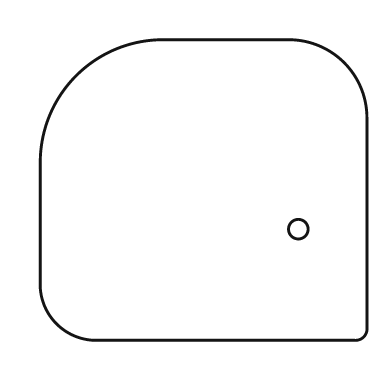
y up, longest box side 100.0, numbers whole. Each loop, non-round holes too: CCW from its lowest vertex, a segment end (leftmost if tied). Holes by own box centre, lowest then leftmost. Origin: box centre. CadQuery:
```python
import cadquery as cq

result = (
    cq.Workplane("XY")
    .moveTo(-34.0, -46.0)
    .lineTo(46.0, -46.0)
    .threePointArc((49.0, -45.0), (50.0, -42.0))
    .lineTo(50.0, 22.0)
    .threePointArc((43.0, 39.0), (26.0, 46.0))
    .lineTo(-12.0, 46.0)
    .threePointArc((-39.0, 35.0), (-50.0, 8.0))
    .lineTo(-50.0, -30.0)
    .threePointArc((-45.0, -41.0), (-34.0, -46.0))
    .close()
    .moveTo(29.0, -12.0)
    .circle(3.0)
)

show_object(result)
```